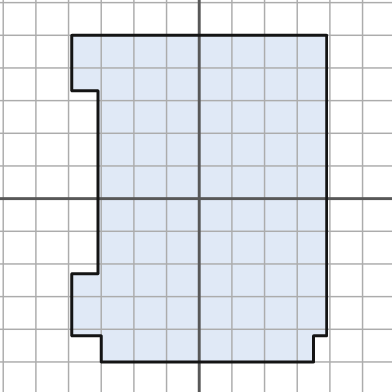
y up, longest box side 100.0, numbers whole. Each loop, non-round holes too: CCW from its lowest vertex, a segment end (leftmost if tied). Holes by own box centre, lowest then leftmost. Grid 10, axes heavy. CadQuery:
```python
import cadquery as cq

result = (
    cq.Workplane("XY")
    .moveTo(-30.0, -50.0)
    .lineTo(35.0, -50.0)
    .lineTo(35.0, -42.0)
    .lineTo(39.0, -42.0)
    .lineTo(39.0, 50.0)
    .lineTo(-39.0, 50.0)
    .lineTo(-39.0, 33.0)
    .lineTo(-31.0, 33.0)
    .lineTo(-31.0, -23.0)
    .lineTo(-39.0, -23.0)
    .lineTo(-39.0, -42.0)
    .lineTo(-30.0, -42.0)
    .close()
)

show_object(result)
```